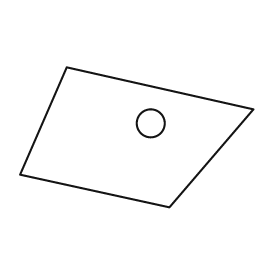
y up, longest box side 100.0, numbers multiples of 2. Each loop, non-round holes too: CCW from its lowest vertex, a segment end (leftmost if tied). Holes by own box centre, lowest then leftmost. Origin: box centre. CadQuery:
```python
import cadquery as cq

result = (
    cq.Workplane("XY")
    .moveTo(14.0, -30.0)
    .lineTo(50.0, 12.0)
    .lineTo(-30.0, 30.0)
    .lineTo(-50.0, -16.0)
    .close()
    .moveTo(6.0, 6.0)
    .circle(6.0)
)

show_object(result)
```